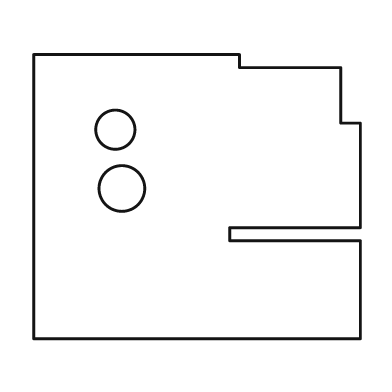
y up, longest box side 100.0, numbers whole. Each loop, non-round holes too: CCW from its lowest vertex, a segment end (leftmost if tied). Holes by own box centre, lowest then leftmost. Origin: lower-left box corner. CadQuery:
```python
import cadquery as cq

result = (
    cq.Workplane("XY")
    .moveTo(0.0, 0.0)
    .lineTo(100.0, 0.0)
    .lineTo(100.0, 30.0)
    .lineTo(60.0, 30.0)
    .lineTo(60.0, 34.0)
    .lineTo(100.0, 34.0)
    .lineTo(100.0, 66.0)
    .lineTo(94.0, 66.0)
    .lineTo(94.0, 83.0)
    .lineTo(63.0, 83.0)
    .lineTo(63.0, 87.0)
    .lineTo(0.0, 87.0)
    .close()
    .moveTo(27.0, 46.0)
    .circle(7.0)
    .moveTo(25.0, 64.0)
    .circle(6.0)
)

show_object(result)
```